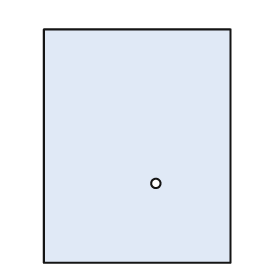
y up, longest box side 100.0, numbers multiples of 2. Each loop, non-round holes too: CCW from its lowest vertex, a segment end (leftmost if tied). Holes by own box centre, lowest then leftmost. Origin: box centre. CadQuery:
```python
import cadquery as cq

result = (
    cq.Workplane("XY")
    .moveTo(-40.0, -50.0)
    .lineTo(40.0, -50.0)
    .lineTo(40.0, 50.0)
    .lineTo(-40.0, 50.0)
    .close()
    .moveTo(8.0, -16.0)
    .circle(2.0)
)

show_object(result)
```